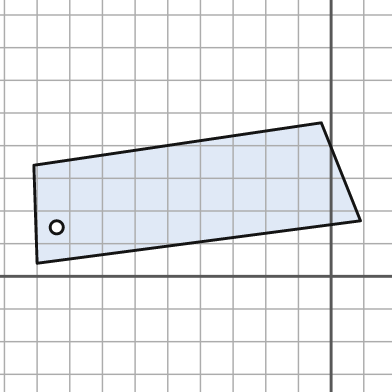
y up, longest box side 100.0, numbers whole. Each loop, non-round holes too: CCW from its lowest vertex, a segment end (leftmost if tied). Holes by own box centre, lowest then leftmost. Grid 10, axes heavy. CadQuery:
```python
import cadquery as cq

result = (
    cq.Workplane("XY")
    .moveTo(-90.0, 4.0)
    .lineTo(9.0, 17.0)
    .lineTo(-3.0, 47.0)
    .lineTo(-91.0, 34.0)
    .close()
    .moveTo(-84.0, 15.0)
    .circle(2.0)
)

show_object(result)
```